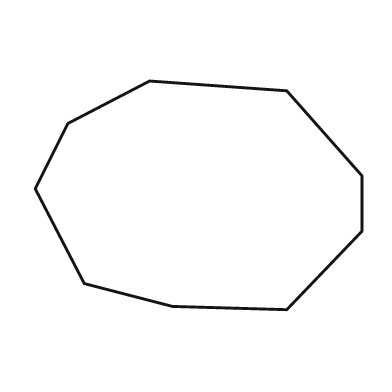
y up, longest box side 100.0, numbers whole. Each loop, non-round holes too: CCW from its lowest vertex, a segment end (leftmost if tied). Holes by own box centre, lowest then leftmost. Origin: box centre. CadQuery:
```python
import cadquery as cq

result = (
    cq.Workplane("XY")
    .moveTo(27.0, -35.0)
    .lineTo(50.0, -11.0)
    .lineTo(50.0, 6.0)
    .lineTo(27.0, 32.0)
    .lineTo(-15.0, 35.0)
    .lineTo(-40.0, 22.0)
    .lineTo(-50.0, 2.0)
    .lineTo(-35.0, -27.0)
    .lineTo(-8.0, -34.0)
    .close()
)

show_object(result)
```